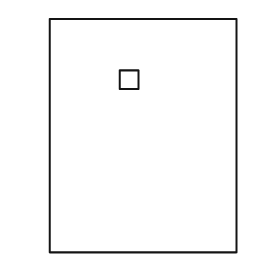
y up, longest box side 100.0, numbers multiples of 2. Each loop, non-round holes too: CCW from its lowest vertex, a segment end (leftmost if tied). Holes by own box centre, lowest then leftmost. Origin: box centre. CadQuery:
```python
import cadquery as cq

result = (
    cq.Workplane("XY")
    .moveTo(-40.0, -50.0)
    .lineTo(40.0, -50.0)
    .lineTo(40.0, 50.0)
    .lineTo(-40.0, 50.0)
    .close()
    .moveTo(-10.0, 20.0)
    .lineTo(-2.0, 20.0)
    .lineTo(-2.0, 28.0)
    .lineTo(-10.0, 28.0)
    .close()
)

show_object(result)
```